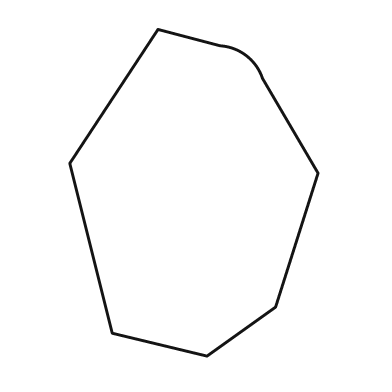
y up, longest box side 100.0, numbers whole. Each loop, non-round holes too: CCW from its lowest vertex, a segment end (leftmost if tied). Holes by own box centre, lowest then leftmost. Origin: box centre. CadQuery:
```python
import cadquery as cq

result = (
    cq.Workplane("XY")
    .moveTo(4.0, -50.0)
    .lineTo(25.0, -35.0)
    .lineTo(38.0, 6.0)
    .lineTo(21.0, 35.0)
    .threePointArc((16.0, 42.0), (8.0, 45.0))
    .lineTo(-11.0, 50.0)
    .lineTo(-38.0, 9.0)
    .lineTo(-25.0, -43.0)
    .close()
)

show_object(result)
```